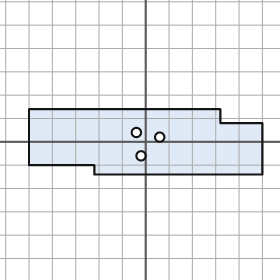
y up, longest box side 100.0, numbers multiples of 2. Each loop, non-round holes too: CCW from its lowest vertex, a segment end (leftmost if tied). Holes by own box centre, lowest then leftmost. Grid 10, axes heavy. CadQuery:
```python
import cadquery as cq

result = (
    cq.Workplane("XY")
    .moveTo(-22.0, -14.0)
    .lineTo(50.0, -14.0)
    .lineTo(50.0, 8.0)
    .lineTo(32.0, 8.0)
    .lineTo(32.0, 14.0)
    .lineTo(-50.0, 14.0)
    .lineTo(-50.0, -10.0)
    .lineTo(-22.0, -10.0)
    .close()
    .moveTo(-2.0, -6.0)
    .circle(2.0)
    .moveTo(6.0, 2.0)
    .circle(2.0)
    .moveTo(-4.0, 4.0)
    .circle(2.0)
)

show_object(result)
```